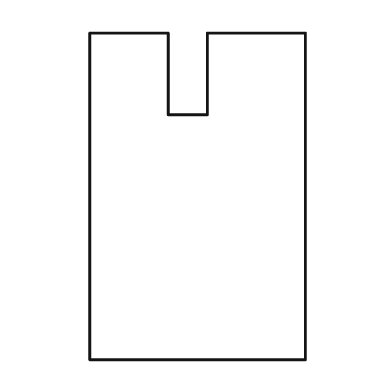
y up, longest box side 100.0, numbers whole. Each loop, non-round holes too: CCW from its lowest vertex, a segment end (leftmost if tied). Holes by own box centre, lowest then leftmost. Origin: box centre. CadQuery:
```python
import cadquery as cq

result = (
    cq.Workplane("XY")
    .moveTo(-33.0, -50.0)
    .lineTo(33.0, -50.0)
    .lineTo(33.0, 50.0)
    .lineTo(3.0, 50.0)
    .lineTo(3.0, 25.0)
    .lineTo(-9.0, 25.0)
    .lineTo(-9.0, 50.0)
    .lineTo(-33.0, 50.0)
    .close()
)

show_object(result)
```